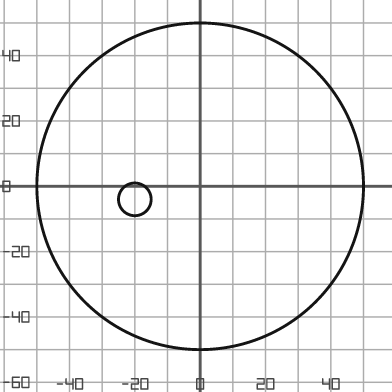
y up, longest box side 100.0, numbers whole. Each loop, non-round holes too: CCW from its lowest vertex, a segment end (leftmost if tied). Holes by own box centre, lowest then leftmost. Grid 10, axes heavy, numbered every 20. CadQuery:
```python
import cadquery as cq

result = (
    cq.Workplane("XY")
    .moveTo(0.0, 0.0)
    .circle(50.0)
    .moveTo(-20.0, -4.0)
    .circle(5.0)
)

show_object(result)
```